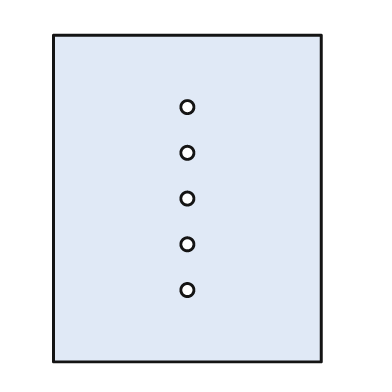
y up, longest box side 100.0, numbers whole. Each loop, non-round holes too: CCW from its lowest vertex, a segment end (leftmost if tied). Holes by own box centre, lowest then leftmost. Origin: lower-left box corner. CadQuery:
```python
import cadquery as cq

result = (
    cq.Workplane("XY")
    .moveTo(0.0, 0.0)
    .lineTo(82.0, 0.0)
    .lineTo(82.0, 100.0)
    .lineTo(0.0, 100.0)
    .close()
    .moveTo(41.0, 22.0)
    .circle(2.0)
    .moveTo(41.0, 36.0)
    .circle(2.0)
    .moveTo(41.0, 50.0)
    .circle(2.0)
    .moveTo(41.0, 64.0)
    .circle(2.0)
    .moveTo(41.0, 78.0)
    .circle(2.0)
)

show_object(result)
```